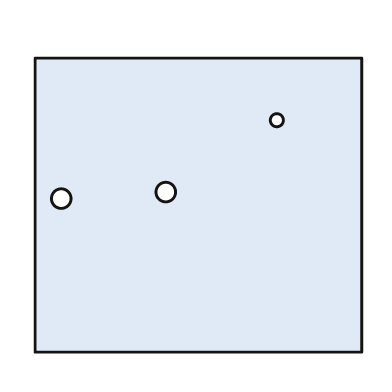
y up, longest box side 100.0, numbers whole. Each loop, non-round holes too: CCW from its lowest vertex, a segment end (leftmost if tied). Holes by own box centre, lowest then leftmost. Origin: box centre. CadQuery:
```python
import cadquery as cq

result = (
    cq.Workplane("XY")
    .moveTo(-50.0, -45.0)
    .lineTo(50.0, -45.0)
    .lineTo(50.0, 45.0)
    .lineTo(-50.0, 45.0)
    .close()
    .moveTo(-42.0, 2.0)
    .circle(3.0)
    .moveTo(-10.0, 4.0)
    .circle(3.0)
    .moveTo(24.0, 26.0)
    .circle(2.0)
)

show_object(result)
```